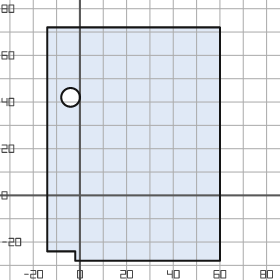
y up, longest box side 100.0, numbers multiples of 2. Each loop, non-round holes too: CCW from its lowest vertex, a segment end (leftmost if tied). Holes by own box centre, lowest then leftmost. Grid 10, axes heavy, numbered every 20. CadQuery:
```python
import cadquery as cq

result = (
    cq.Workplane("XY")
    .moveTo(-2.0, -28.0)
    .lineTo(60.0, -28.0)
    .lineTo(60.0, 72.0)
    .lineTo(-14.0, 72.0)
    .lineTo(-14.0, -24.0)
    .lineTo(-2.0, -24.0)
    .close()
    .moveTo(-4.0, 42.0)
    .circle(4.0)
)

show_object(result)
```